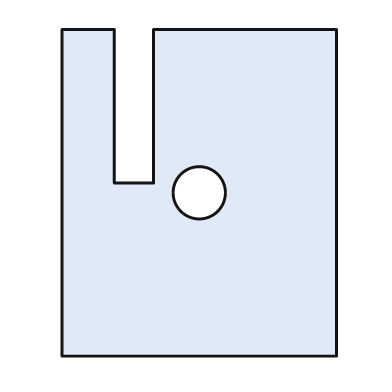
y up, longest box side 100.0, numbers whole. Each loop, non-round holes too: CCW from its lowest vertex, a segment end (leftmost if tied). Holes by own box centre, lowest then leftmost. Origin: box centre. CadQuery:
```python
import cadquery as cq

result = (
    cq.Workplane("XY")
    .moveTo(-42.0, -50.0)
    .lineTo(42.0, -50.0)
    .lineTo(42.0, 50.0)
    .lineTo(-14.0, 50.0)
    .lineTo(-14.0, 3.0)
    .lineTo(-26.0, 3.0)
    .lineTo(-26.0, 50.0)
    .lineTo(-42.0, 50.0)
    .close()
    .moveTo(0.0, 0.0)
    .circle(8.0)
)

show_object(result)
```